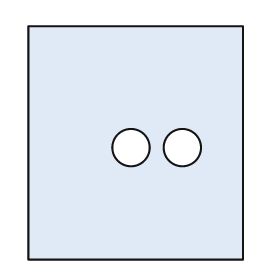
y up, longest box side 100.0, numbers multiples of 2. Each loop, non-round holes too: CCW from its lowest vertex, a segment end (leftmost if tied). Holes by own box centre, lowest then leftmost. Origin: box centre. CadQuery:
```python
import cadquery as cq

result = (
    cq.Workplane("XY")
    .moveTo(-46.0, -50.0)
    .lineTo(46.0, -50.0)
    .lineTo(46.0, 50.0)
    .lineTo(-46.0, 50.0)
    .close()
    .moveTo(-2.0, -2.0)
    .circle(8.0)
    .moveTo(20.0, -2.0)
    .circle(8.0)
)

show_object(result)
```